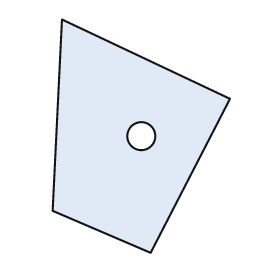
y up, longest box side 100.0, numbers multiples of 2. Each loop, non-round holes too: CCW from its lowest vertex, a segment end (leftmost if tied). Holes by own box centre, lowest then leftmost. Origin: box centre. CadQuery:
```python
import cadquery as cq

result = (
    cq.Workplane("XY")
    .moveTo(4.0, -50.0)
    .lineTo(38.0, 16.0)
    .lineTo(-34.0, 50.0)
    .lineTo(-38.0, -32.0)
    .close()
    .moveTo(0.0, 0.0)
    .circle(6.0)
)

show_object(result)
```